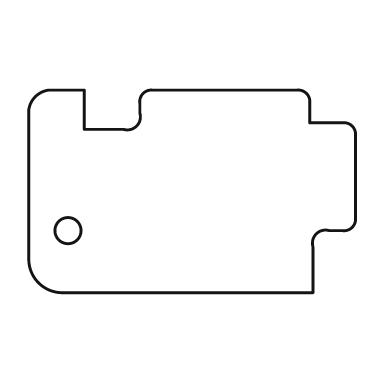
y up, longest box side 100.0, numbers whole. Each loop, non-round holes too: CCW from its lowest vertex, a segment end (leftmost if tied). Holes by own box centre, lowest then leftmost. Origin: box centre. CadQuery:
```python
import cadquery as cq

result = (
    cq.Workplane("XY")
    .moveTo(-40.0, -31.0)
    .lineTo(37.0, -31.0)
    .lineTo(37.0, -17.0)
    .threePointArc((38.0, -13.0), (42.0, -12.0))
    .lineTo(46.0, -12.0)
    .threePointArc((49.0, -11.0), (50.0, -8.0))
    .lineTo(50.0, 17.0)
    .threePointArc((49.0, 20.0), (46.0, 21.0))
    .lineTo(36.0, 21.0)
    .lineTo(36.0, 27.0)
    .threePointArc((35.0, 30.0), (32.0, 31.0))
    .lineTo(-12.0, 31.0)
    .threePointArc((-15.0, 30.0), (-16.0, 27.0))
    .lineTo(-16.0, 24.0)
    .threePointArc((-17.0, 20.0), (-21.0, 19.0))
    .lineTo(-33.0, 19.0)
    .lineTo(-33.0, 31.0)
    .lineTo(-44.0, 31.0)
    .threePointArc((-48.0, 29.0), (-50.0, 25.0))
    .lineTo(-50.0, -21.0)
    .threePointArc((-47.0, -28.0), (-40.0, -31.0))
    .close()
    .moveTo(-38.0, -12.0)
    .circle(4.0)
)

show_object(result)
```